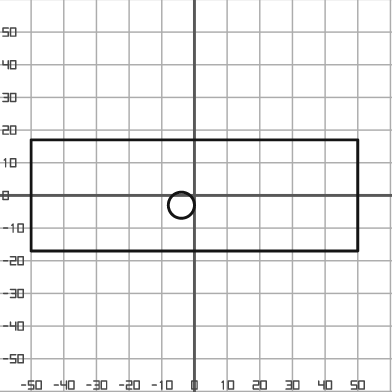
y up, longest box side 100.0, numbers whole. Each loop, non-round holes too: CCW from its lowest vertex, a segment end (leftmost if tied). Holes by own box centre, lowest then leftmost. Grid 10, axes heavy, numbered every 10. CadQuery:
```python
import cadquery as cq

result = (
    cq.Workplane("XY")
    .moveTo(-50.0, -17.0)
    .lineTo(50.0, -17.0)
    .lineTo(50.0, 17.0)
    .lineTo(-50.0, 17.0)
    .close()
    .moveTo(-4.0, -3.0)
    .circle(4.0)
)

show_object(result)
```